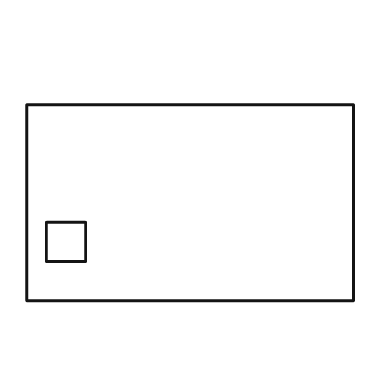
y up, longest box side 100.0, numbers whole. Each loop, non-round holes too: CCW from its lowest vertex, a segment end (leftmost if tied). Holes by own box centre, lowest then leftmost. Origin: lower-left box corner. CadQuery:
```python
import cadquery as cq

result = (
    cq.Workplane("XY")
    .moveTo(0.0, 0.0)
    .lineTo(100.0, 0.0)
    .lineTo(100.0, 60.0)
    .lineTo(0.0, 60.0)
    .close()
    .moveTo(6.0, 12.0)
    .lineTo(18.0, 12.0)
    .lineTo(18.0, 24.0)
    .lineTo(6.0, 24.0)
    .close()
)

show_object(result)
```